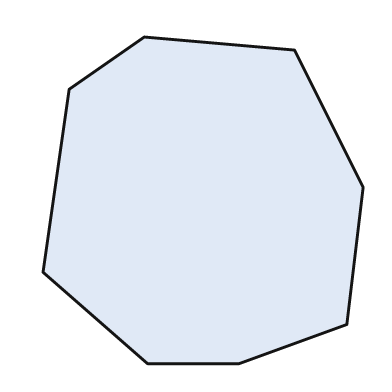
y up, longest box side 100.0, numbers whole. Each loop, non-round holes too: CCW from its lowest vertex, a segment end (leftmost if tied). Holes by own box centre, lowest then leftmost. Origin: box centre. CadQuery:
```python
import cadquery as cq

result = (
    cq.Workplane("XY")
    .moveTo(-17.0, -50.0)
    .lineTo(11.0, -50.0)
    .lineTo(44.0, -38.0)
    .lineTo(49.0, 4.0)
    .lineTo(28.0, 46.0)
    .lineTo(-18.0, 50.0)
    .lineTo(-41.0, 34.0)
    .lineTo(-49.0, -22.0)
    .close()
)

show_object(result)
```